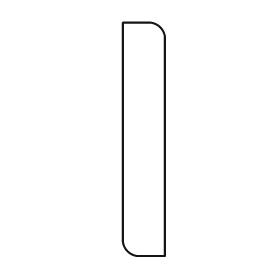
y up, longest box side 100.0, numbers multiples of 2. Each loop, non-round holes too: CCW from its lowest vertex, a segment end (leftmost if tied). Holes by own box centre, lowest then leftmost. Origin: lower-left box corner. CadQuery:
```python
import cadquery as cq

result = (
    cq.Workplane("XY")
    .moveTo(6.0, 0.0)
    .lineTo(18.0, 0.0)
    .lineTo(18.0, 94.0)
    .threePointArc((16.0, 98.0), (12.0, 100.0))
    .lineTo(0.0, 100.0)
    .lineTo(0.0, 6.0)
    .threePointArc((2.0, 2.0), (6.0, 0.0))
    .close()
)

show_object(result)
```